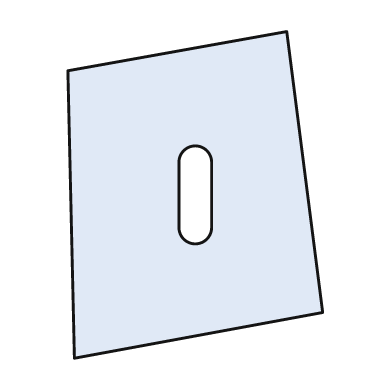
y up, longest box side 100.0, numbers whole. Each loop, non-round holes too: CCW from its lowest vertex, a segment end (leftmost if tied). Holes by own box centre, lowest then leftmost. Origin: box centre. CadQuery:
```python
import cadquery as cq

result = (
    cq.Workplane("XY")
    .moveTo(-37.0, -50.0)
    .lineTo(39.0, -36.0)
    .lineTo(28.0, 50.0)
    .lineTo(-39.0, 38.0)
    .close()
    .moveTo(-5.0, -10.0)
    .threePointArc((0.0, -15.0), (5.0, -10.0))
    .lineTo(5.0, 10.0)
    .threePointArc((0.0, 15.0), (-5.0, 10.0))
    .close()
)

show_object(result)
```